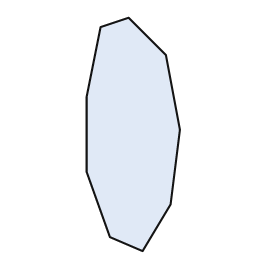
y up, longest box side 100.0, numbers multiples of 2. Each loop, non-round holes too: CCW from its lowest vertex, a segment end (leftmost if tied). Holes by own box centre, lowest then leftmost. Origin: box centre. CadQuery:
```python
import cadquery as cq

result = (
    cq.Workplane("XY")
    .moveTo(4.0, -50.0)
    .lineTo(16.0, -30.0)
    .lineTo(20.0, 2.0)
    .lineTo(14.0, 34.0)
    .lineTo(-2.0, 50.0)
    .lineTo(-14.0, 46.0)
    .lineTo(-20.0, 16.0)
    .lineTo(-20.0, -16.0)
    .lineTo(-10.0, -44.0)
    .close()
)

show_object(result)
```